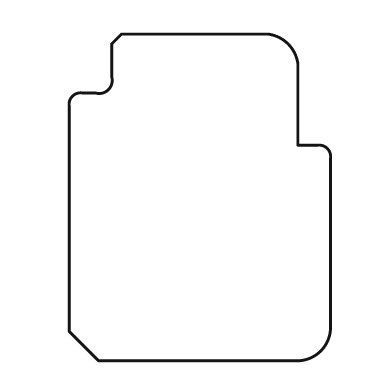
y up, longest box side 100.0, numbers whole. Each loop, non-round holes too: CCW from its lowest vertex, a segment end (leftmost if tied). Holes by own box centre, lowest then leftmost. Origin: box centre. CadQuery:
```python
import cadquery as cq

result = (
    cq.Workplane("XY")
    .moveTo(-31.0, -50.0)
    .lineTo(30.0, -50.0)
    .threePointArc((37.0, -47.0), (40.0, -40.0))
    .lineTo(40.0, 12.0)
    .threePointArc((39.0, 15.0), (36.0, 16.0))
    .lineTo(30.0, 16.0)
    .lineTo(30.0, 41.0)
    .threePointArc((27.0, 47.0), (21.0, 50.0))
    .lineTo(-24.0, 50.0)
    .lineTo(-27.0, 47.0)
    .lineTo(-27.0, 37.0)
    .threePointArc((-28.0, 33.0), (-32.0, 32.0))
    .lineTo(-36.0, 32.0)
    .threePointArc((-39.0, 31.0), (-40.0, 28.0))
    .lineTo(-40.0, -41.0)
    .close()
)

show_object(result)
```